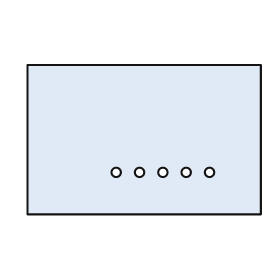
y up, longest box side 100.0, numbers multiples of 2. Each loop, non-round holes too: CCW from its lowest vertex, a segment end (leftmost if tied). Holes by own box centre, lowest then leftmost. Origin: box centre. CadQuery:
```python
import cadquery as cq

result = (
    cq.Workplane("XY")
    .moveTo(-50.0, -32.0)
    .lineTo(50.0, -32.0)
    .lineTo(50.0, 32.0)
    .lineTo(-50.0, 32.0)
    .close()
    .moveTo(-12.0, -14.0)
    .circle(2.0)
    .moveTo(-2.0, -14.0)
    .circle(2.0)
    .moveTo(8.0, -14.0)
    .circle(2.0)
    .moveTo(18.0, -14.0)
    .circle(2.0)
    .moveTo(28.0, -14.0)
    .circle(2.0)
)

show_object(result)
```